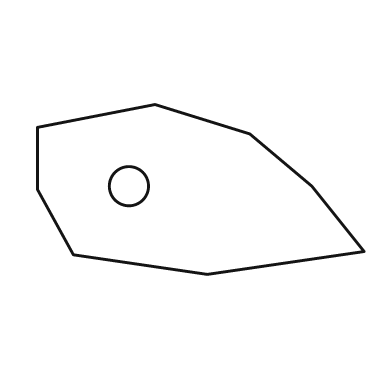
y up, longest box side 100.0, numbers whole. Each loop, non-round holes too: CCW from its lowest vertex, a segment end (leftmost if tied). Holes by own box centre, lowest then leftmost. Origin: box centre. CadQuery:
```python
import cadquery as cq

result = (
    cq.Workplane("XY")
    .moveTo(2.0, -26.0)
    .lineTo(50.0, -19.0)
    .lineTo(34.0, 1.0)
    .lineTo(15.0, 17.0)
    .lineTo(-14.0, 26.0)
    .lineTo(-50.0, 19.0)
    .lineTo(-50.0, 0.0)
    .lineTo(-39.0, -20.0)
    .close()
    .moveTo(-22.0, 1.0)
    .circle(6.0)
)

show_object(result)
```